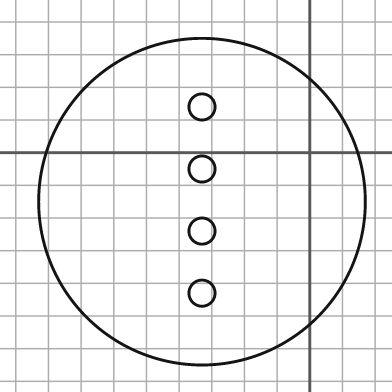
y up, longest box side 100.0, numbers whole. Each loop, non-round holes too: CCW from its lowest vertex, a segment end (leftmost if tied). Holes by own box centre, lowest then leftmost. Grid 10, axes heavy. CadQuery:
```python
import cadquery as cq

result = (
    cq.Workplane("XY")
    .moveTo(-33.0, -15.0)
    .circle(50.0)
    .moveTo(-33.0, -43.0)
    .circle(4.0)
    .moveTo(-33.0, -24.0)
    .circle(4.0)
    .moveTo(-33.0, -5.0)
    .circle(4.0)
    .moveTo(-33.0, 14.0)
    .circle(4.0)
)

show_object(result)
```